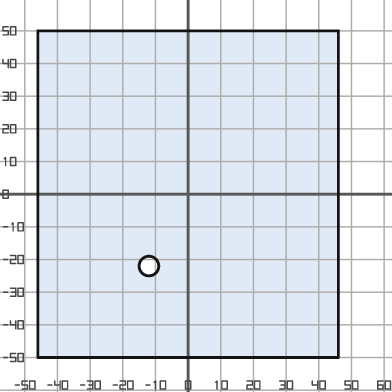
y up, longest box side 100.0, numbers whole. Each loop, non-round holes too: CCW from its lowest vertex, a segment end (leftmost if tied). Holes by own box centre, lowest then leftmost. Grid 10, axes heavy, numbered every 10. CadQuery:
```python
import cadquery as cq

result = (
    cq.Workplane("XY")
    .moveTo(-46.0, -50.0)
    .lineTo(46.0, -50.0)
    .lineTo(46.0, 50.0)
    .lineTo(-46.0, 50.0)
    .close()
    .moveTo(-12.0, -22.0)
    .circle(3.0)
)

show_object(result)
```